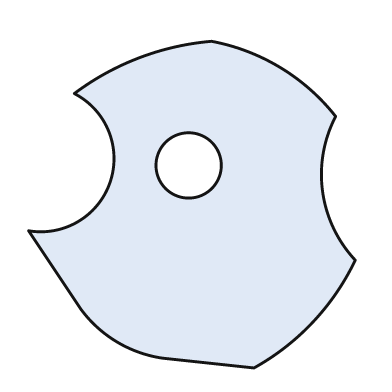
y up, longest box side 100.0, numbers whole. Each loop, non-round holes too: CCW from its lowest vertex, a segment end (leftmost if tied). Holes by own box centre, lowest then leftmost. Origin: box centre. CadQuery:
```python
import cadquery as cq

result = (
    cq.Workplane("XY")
    .moveTo(19.0, -50.0)
    .threePointArc((37.0, -36.0), (50.0, -17.0))
    .threePointArc((40.0, 4.0), (44.0, 27.0))
    .threePointArc((27.0, 42.0), (6.0, 50.0))
    .threePointArc((-16.0, 45.0), (-36.0, 34.0))
    .threePointArc((-25.0, 7.0), (-50.0, -8.0))
    .lineTo(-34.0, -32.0)
    .threePointArc((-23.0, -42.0), (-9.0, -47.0))
    .close()
    .moveTo(-1.0, 12.0)
    .circle(10.0)
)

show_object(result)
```